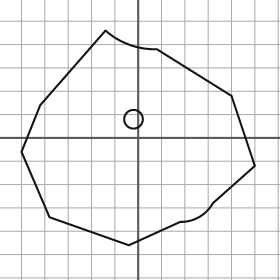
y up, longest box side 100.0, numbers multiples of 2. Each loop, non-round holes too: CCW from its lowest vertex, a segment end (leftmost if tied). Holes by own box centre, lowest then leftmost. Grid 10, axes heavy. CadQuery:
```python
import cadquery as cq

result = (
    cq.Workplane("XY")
    .moveTo(-4.0, -46.0)
    .lineTo(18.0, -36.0)
    .threePointArc((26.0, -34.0), (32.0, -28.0))
    .lineTo(50.0, -12.0)
    .lineTo(40.0, 18.0)
    .lineTo(8.0, 38.0)
    .threePointArc((-4.0, 40.0), (-14.0, 46.0))
    .lineTo(-42.0, 14.0)
    .lineTo(-50.0, -6.0)
    .lineTo(-38.0, -34.0)
    .close()
    .moveTo(-2.0, 8.0)
    .circle(4.0)
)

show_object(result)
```